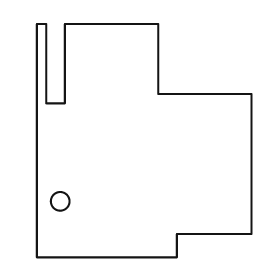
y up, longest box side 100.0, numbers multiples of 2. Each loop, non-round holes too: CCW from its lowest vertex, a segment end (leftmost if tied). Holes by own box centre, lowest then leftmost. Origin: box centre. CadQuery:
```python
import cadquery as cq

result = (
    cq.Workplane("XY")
    .moveTo(-46.0, -50.0)
    .lineTo(14.0, -50.0)
    .lineTo(14.0, -40.0)
    .lineTo(46.0, -40.0)
    .lineTo(46.0, 20.0)
    .lineTo(6.0, 20.0)
    .lineTo(6.0, 50.0)
    .lineTo(-34.0, 50.0)
    .lineTo(-34.0, 16.0)
    .lineTo(-42.0, 16.0)
    .lineTo(-42.0, 50.0)
    .lineTo(-46.0, 50.0)
    .close()
    .moveTo(-36.0, -26.0)
    .circle(4.0)
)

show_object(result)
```